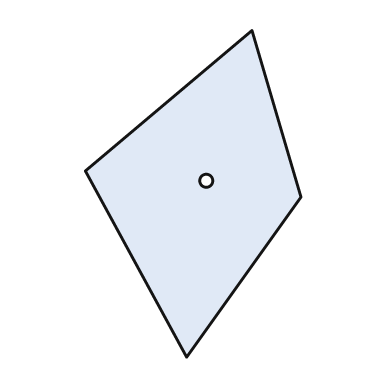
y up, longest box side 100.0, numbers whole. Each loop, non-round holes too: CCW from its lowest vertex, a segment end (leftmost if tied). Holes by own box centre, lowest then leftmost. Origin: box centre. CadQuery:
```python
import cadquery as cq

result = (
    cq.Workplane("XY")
    .moveTo(-2.0, -50.0)
    .lineTo(33.0, -1.0)
    .lineTo(18.0, 50.0)
    .lineTo(-33.0, 7.0)
    .close()
    .moveTo(4.0, 4.0)
    .circle(2.0)
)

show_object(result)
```